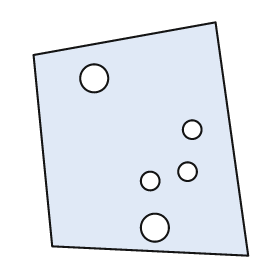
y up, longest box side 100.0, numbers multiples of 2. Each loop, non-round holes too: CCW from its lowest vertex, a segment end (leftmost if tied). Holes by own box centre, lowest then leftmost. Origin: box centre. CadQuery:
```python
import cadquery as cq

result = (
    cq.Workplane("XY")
    .moveTo(46.0, -50.0)
    .lineTo(32.0, 50.0)
    .lineTo(-46.0, 36.0)
    .lineTo(-38.0, -46.0)
    .close()
    .moveTo(6.0, -38.0)
    .circle(6.0)
    .moveTo(4.0, -18.0)
    .circle(4.0)
    .moveTo(20.0, -14.0)
    .circle(4.0)
    .moveTo(22.0, 4.0)
    .circle(4.0)
    .moveTo(-20.0, 26.0)
    .circle(6.0)
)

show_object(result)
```